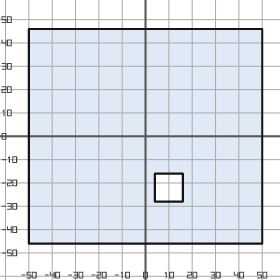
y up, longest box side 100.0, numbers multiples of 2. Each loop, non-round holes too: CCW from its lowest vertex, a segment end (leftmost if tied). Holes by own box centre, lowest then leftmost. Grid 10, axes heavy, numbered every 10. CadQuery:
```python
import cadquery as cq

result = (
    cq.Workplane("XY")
    .moveTo(-50.0, -46.0)
    .lineTo(50.0, -46.0)
    .lineTo(50.0, 46.0)
    .lineTo(-50.0, 46.0)
    .close()
    .moveTo(4.0, -28.0)
    .lineTo(16.0, -28.0)
    .lineTo(16.0, -16.0)
    .lineTo(4.0, -16.0)
    .close()
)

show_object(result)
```